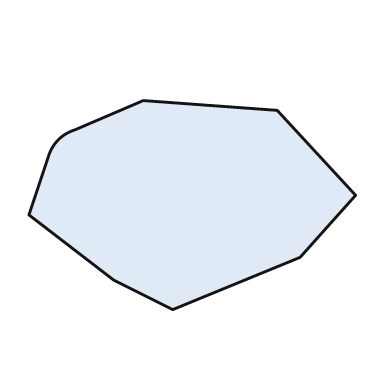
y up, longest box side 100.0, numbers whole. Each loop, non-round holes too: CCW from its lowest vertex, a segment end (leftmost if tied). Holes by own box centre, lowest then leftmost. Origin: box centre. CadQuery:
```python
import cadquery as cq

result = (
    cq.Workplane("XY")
    .moveTo(-6.0, -32.0)
    .lineTo(33.0, -16.0)
    .lineTo(50.0, 3.0)
    .lineTo(26.0, 29.0)
    .lineTo(-15.0, 32.0)
    .lineTo(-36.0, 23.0)
    .threePointArc((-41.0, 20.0), (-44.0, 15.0))
    .lineTo(-50.0, -3.0)
    .lineTo(-24.0, -23.0)
    .close()
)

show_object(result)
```